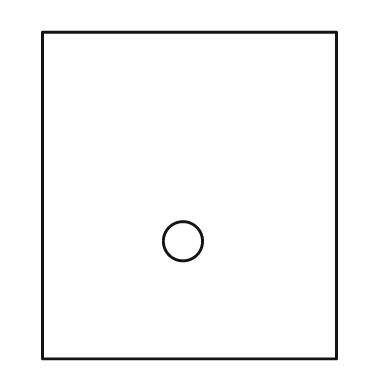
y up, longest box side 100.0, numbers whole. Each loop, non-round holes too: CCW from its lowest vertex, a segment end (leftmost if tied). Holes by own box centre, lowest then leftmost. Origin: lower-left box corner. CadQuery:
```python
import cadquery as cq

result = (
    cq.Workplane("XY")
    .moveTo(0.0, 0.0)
    .lineTo(90.0, 0.0)
    .lineTo(90.0, 100.0)
    .lineTo(0.0, 100.0)
    .close()
    .moveTo(43.0, 36.0)
    .circle(6.0)
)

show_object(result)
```